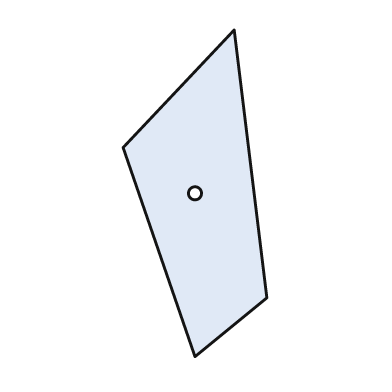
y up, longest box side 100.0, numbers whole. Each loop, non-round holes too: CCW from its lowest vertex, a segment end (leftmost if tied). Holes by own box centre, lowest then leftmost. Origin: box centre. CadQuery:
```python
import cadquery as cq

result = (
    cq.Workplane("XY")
    .moveTo(0.0, -50.0)
    .lineTo(22.0, -32.0)
    .lineTo(12.0, 50.0)
    .lineTo(-22.0, 14.0)
    .close()
    .moveTo(0.0, 0.0)
    .circle(2.0)
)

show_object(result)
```